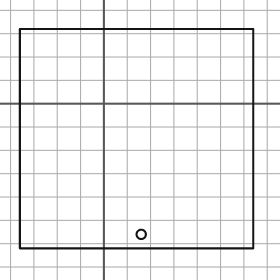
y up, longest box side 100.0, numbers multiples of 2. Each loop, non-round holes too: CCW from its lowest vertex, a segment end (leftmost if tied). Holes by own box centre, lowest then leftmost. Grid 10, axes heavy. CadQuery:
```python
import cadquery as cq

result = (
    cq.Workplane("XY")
    .moveTo(-36.0, -62.0)
    .lineTo(64.0, -62.0)
    .lineTo(64.0, 32.0)
    .lineTo(-36.0, 32.0)
    .close()
    .moveTo(16.0, -56.0)
    .circle(2.0)
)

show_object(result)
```